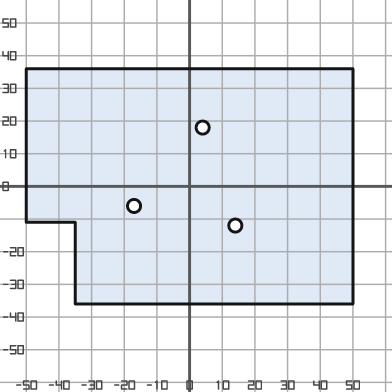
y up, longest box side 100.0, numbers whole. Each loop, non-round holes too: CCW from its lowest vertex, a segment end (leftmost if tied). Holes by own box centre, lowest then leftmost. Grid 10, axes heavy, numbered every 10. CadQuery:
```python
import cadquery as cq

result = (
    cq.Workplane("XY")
    .moveTo(-35.0, -36.0)
    .lineTo(50.0, -36.0)
    .lineTo(50.0, 36.0)
    .lineTo(-50.0, 36.0)
    .lineTo(-50.0, -11.0)
    .lineTo(-35.0, -11.0)
    .close()
    .moveTo(14.0, -12.0)
    .circle(2.0)
    .moveTo(-17.0, -6.0)
    .circle(2.0)
    .moveTo(4.0, 18.0)
    .circle(2.0)
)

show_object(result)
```